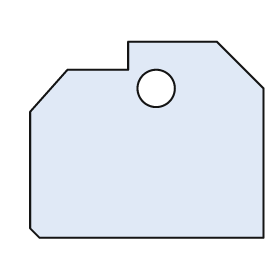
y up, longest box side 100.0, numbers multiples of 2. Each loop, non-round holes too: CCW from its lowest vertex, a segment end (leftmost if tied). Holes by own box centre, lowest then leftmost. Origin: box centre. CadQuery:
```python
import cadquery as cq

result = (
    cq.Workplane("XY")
    .moveTo(-46.0, -42.0)
    .lineTo(50.0, -42.0)
    .lineTo(50.0, 22.0)
    .lineTo(30.0, 42.0)
    .lineTo(-8.0, 42.0)
    .lineTo(-8.0, 30.0)
    .lineTo(-34.0, 30.0)
    .lineTo(-50.0, 12.0)
    .lineTo(-50.0, -38.0)
    .close()
    .moveTo(4.0, 22.0)
    .circle(8.0)
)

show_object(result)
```